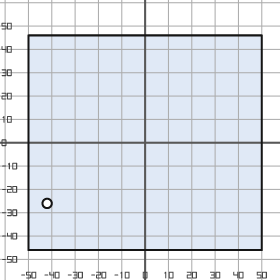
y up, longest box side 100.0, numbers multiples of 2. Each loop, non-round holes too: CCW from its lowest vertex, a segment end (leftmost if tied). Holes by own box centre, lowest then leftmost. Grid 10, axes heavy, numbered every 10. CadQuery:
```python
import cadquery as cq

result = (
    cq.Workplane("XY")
    .moveTo(-50.0, -46.0)
    .lineTo(50.0, -46.0)
    .lineTo(50.0, 46.0)
    .lineTo(-50.0, 46.0)
    .close()
    .moveTo(-42.0, -26.0)
    .circle(2.0)
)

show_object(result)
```